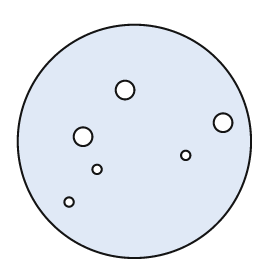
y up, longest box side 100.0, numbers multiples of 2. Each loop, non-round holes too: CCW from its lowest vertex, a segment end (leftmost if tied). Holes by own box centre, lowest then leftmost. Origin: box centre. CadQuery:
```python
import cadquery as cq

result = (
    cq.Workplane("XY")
    .moveTo(0.0, 0.0)
    .circle(50.0)
    .moveTo(-28.0, -26.0)
    .circle(2.0)
    .moveTo(-16.0, -12.0)
    .circle(2.0)
    .moveTo(22.0, -6.0)
    .circle(2.0)
    .moveTo(-22.0, 2.0)
    .circle(4.0)
    .moveTo(38.0, 8.0)
    .circle(4.0)
    .moveTo(-4.0, 22.0)
    .circle(4.0)
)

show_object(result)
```